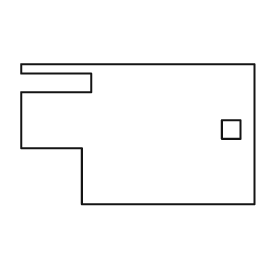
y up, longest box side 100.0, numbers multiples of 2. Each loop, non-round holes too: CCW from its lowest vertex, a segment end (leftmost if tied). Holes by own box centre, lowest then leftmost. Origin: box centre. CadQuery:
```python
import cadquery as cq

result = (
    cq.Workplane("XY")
    .moveTo(-24.0, -30.0)
    .lineTo(50.0, -30.0)
    .lineTo(50.0, 30.0)
    .lineTo(-50.0, 30.0)
    .lineTo(-50.0, 26.0)
    .lineTo(-20.0, 26.0)
    .lineTo(-20.0, 18.0)
    .lineTo(-50.0, 18.0)
    .lineTo(-50.0, -6.0)
    .lineTo(-24.0, -6.0)
    .close()
    .moveTo(36.0, -2.0)
    .lineTo(44.0, -2.0)
    .lineTo(44.0, 6.0)
    .lineTo(36.0, 6.0)
    .close()
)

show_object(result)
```